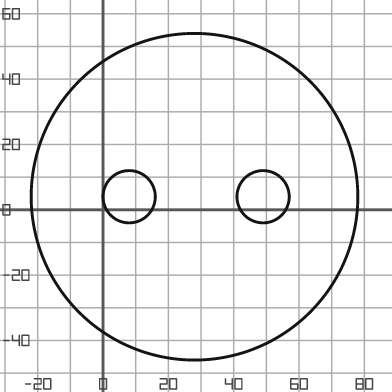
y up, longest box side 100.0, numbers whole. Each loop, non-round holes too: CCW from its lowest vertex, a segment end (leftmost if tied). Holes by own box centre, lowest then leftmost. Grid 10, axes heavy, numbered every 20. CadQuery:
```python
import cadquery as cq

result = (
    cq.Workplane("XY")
    .moveTo(28.0, 4.0)
    .circle(50.0)
    .moveTo(8.0, 4.0)
    .circle(8.0)
    .moveTo(49.0, 4.0)
    .circle(8.0)
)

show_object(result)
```